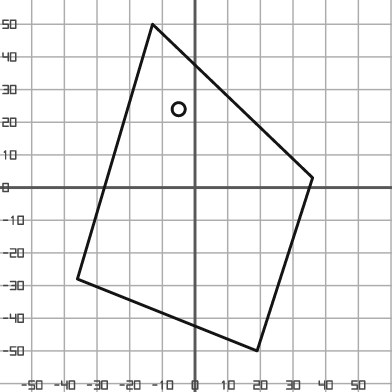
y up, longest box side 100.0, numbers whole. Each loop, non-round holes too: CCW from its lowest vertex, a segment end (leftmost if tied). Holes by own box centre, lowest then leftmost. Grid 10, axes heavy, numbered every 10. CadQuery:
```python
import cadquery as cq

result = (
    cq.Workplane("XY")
    .moveTo(19.0, -50.0)
    .lineTo(36.0, 3.0)
    .lineTo(-13.0, 50.0)
    .lineTo(-36.0, -28.0)
    .close()
    .moveTo(-5.0, 24.0)
    .circle(2.0)
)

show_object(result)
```